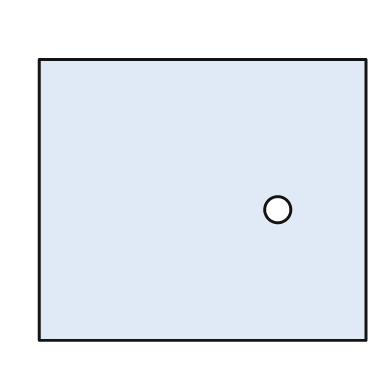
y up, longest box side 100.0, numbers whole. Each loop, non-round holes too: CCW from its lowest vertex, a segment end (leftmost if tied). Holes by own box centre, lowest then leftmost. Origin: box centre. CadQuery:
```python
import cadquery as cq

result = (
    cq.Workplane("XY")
    .moveTo(-50.0, -43.0)
    .lineTo(50.0, -43.0)
    .lineTo(50.0, 43.0)
    .lineTo(-50.0, 43.0)
    .close()
    .moveTo(23.0, -3.0)
    .circle(4.0)
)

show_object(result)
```